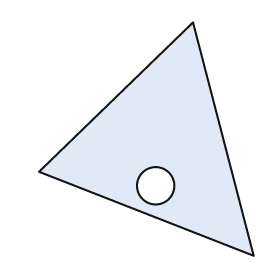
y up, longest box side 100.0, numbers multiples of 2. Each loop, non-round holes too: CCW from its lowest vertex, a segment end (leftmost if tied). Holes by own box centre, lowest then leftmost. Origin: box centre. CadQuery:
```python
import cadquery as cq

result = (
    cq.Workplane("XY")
    .moveTo(46.0, -50.0)
    .lineTo(20.0, 50.0)
    .lineTo(-46.0, -14.0)
    .close()
    .moveTo(4.0, -20.0)
    .circle(8.0)
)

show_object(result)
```